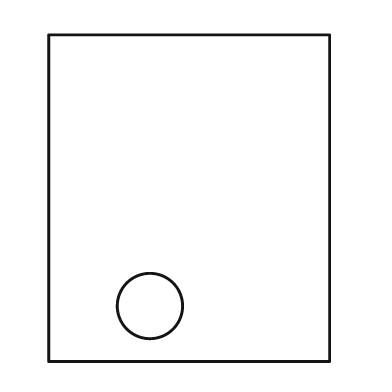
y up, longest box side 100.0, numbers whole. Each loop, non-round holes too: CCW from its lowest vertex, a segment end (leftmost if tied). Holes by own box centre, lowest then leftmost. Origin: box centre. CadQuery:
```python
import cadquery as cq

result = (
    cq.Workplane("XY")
    .moveTo(-43.0, -50.0)
    .lineTo(43.0, -50.0)
    .lineTo(43.0, 50.0)
    .lineTo(-43.0, 50.0)
    .close()
    .moveTo(-12.0, -33.0)
    .circle(10.0)
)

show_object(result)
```